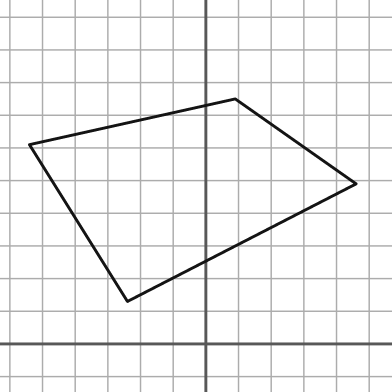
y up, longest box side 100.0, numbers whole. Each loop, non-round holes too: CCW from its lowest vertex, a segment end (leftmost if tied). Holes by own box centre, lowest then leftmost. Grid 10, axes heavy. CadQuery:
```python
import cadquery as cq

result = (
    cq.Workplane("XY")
    .moveTo(-24.0, 13.0)
    .lineTo(46.0, 49.0)
    .lineTo(9.0, 75.0)
    .lineTo(-54.0, 61.0)
    .close()
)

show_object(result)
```